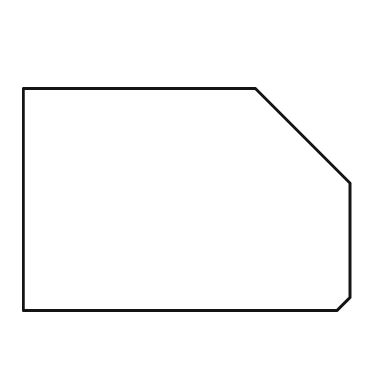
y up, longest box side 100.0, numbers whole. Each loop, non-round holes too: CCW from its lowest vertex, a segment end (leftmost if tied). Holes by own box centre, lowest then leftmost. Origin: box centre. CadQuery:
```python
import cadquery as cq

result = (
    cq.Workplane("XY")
    .moveTo(-50.0, -34.0)
    .lineTo(46.0, -34.0)
    .lineTo(50.0, -30.0)
    .lineTo(50.0, 5.0)
    .lineTo(21.0, 34.0)
    .lineTo(-50.0, 34.0)
    .close()
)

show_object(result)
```